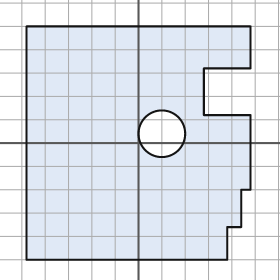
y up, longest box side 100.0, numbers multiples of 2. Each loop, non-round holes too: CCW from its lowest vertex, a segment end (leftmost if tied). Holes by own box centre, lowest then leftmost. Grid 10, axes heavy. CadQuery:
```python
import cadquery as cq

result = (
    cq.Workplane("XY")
    .moveTo(-48.0, -50.0)
    .lineTo(38.0, -50.0)
    .lineTo(38.0, -36.0)
    .lineTo(44.0, -36.0)
    .lineTo(44.0, -20.0)
    .lineTo(48.0, -20.0)
    .lineTo(48.0, 12.0)
    .lineTo(28.0, 12.0)
    .lineTo(28.0, 32.0)
    .lineTo(48.0, 32.0)
    .lineTo(48.0, 50.0)
    .lineTo(-48.0, 50.0)
    .close()
    .moveTo(10.0, 4.0)
    .circle(10.0)
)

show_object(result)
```